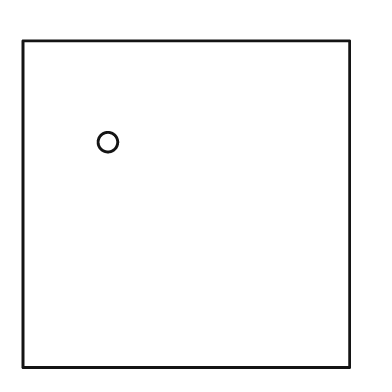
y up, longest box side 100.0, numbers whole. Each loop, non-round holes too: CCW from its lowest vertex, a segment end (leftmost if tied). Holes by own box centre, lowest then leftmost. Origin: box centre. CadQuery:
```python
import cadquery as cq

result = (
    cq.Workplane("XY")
    .moveTo(-50.0, -50.0)
    .lineTo(50.0, -50.0)
    .lineTo(50.0, 50.0)
    .lineTo(-50.0, 50.0)
    .close()
    .moveTo(-24.0, 19.0)
    .circle(3.0)
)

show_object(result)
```